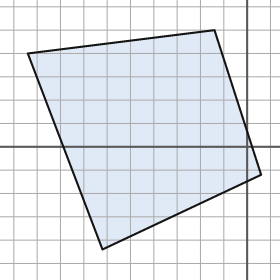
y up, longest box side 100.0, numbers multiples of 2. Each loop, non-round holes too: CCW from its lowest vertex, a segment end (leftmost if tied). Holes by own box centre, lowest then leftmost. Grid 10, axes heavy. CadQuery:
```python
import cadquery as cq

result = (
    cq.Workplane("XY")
    .moveTo(-62.0, -44.0)
    .lineTo(6.0, -12.0)
    .lineTo(-14.0, 50.0)
    .lineTo(-94.0, 40.0)
    .close()
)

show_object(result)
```